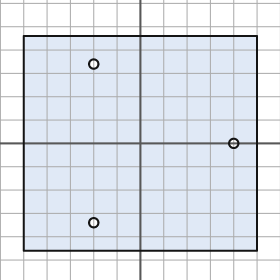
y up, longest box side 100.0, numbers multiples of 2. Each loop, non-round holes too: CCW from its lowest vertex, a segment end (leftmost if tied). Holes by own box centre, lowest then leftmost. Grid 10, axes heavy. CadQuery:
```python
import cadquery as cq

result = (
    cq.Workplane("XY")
    .moveTo(-50.0, -46.0)
    .lineTo(50.0, -46.0)
    .lineTo(50.0, 46.0)
    .lineTo(-50.0, 46.0)
    .close()
    .moveTo(-20.0, -34.0)
    .circle(2.0)
    .moveTo(40.0, 0.0)
    .circle(2.0)
    .moveTo(-20.0, 34.0)
    .circle(2.0)
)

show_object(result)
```